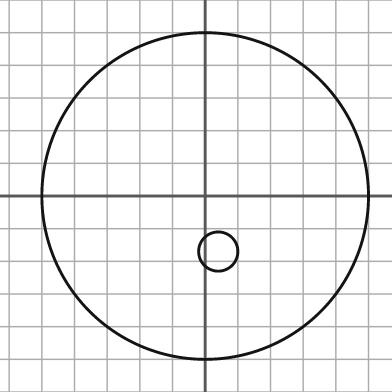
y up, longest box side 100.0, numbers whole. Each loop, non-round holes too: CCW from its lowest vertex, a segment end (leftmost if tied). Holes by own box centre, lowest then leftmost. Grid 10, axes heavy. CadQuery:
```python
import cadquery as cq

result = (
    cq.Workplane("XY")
    .moveTo(0.0, 0.0)
    .circle(50.0)
    .moveTo(4.0, -17.0)
    .circle(6.0)
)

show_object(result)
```